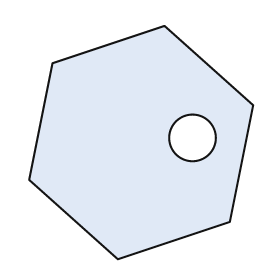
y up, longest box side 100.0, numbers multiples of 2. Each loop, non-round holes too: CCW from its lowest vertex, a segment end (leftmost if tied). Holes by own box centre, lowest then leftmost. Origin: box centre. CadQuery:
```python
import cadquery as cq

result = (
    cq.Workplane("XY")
    .moveTo(-10.0, -50.0)
    .lineTo(38.0, -34.0)
    .lineTo(48.0, 16.0)
    .lineTo(10.0, 50.0)
    .lineTo(-38.0, 34.0)
    .lineTo(-48.0, -16.0)
    .close()
    .moveTo(22.0, 2.0)
    .circle(10.0)
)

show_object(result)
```